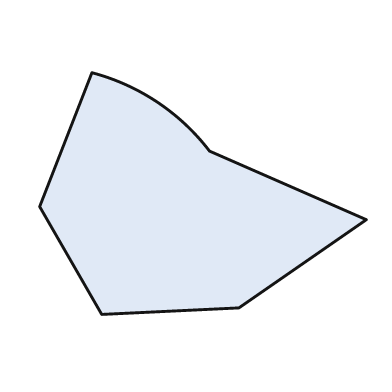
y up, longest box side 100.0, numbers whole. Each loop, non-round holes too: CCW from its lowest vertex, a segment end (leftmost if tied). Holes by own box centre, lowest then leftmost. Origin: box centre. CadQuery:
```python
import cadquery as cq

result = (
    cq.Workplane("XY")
    .moveTo(-31.0, -37.0)
    .lineTo(11.0, -35.0)
    .lineTo(50.0, -8.0)
    .lineTo(2.0, 13.0)
    .threePointArc((-14.0, 28.0), (-34.0, 37.0))
    .lineTo(-50.0, -4.0)
    .close()
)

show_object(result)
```